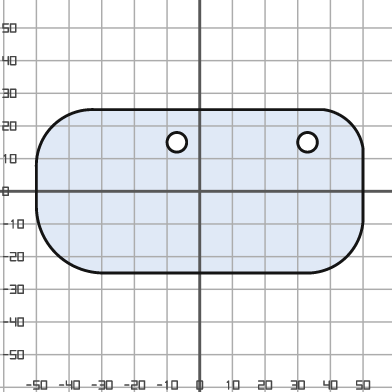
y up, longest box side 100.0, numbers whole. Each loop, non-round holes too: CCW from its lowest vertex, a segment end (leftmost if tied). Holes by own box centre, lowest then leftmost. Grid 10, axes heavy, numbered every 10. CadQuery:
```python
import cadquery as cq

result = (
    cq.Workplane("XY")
    .moveTo(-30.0, -25.0)
    .lineTo(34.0, -25.0)
    .threePointArc((45.0, -20.0), (50.0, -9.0))
    .lineTo(50.0, 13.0)
    .threePointArc((46.0, 21.0), (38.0, 25.0))
    .lineTo(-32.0, 25.0)
    .threePointArc((-45.0, 20.0), (-50.0, 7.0))
    .lineTo(-50.0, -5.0)
    .threePointArc((-44.0, -19.0), (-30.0, -25.0))
    .close()
    .moveTo(-7.0, 15.0)
    .circle(3.0)
    .moveTo(33.0, 15.0)
    .circle(3.0)
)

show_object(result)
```